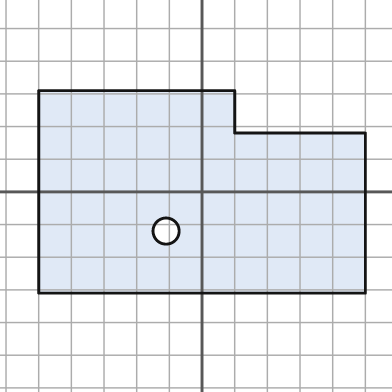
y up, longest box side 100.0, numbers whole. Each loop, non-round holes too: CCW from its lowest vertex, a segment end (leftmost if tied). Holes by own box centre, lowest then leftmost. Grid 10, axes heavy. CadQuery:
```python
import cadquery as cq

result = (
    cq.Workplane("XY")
    .moveTo(-50.0, -31.0)
    .lineTo(50.0, -31.0)
    .lineTo(50.0, 18.0)
    .lineTo(10.0, 18.0)
    .lineTo(10.0, 31.0)
    .lineTo(-50.0, 31.0)
    .close()
    .moveTo(-11.0, -12.0)
    .circle(4.0)
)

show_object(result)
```